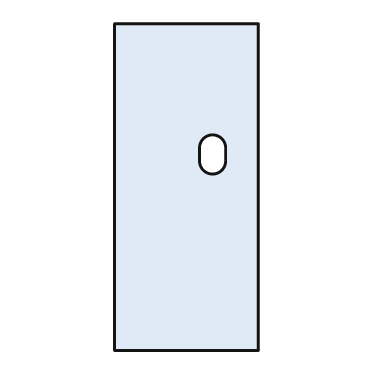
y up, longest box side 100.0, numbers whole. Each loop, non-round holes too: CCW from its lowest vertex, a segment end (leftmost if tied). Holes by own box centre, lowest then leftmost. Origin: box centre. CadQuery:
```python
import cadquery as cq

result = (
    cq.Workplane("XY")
    .moveTo(-22.0, -50.0)
    .lineTo(22.0, -50.0)
    .lineTo(22.0, 50.0)
    .lineTo(-22.0, 50.0)
    .close()
    .moveTo(4.0, 8.0)
    .threePointArc((8.0, 4.0), (12.0, 8.0))
    .lineTo(12.0, 12.0)
    .threePointArc((8.0, 16.0), (4.0, 12.0))
    .close()
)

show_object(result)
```